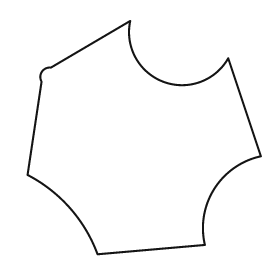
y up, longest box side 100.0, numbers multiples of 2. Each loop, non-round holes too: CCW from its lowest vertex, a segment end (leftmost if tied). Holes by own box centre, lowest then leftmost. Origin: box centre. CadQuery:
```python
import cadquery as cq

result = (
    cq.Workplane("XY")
    .moveTo(-20.0, -50.0)
    .lineTo(26.0, -46.0)
    .threePointArc((30.0, -22.0), (50.0, -8.0))
    .lineTo(36.0, 34.0)
    .threePointArc((8.0, 24.0), (-6.0, 50.0))
    .lineTo(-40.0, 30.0)
    .threePointArc((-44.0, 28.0), (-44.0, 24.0))
    .lineTo(-50.0, -16.0)
    .threePointArc((-32.0, -30.0), (-20.0, -50.0))
    .close()
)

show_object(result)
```